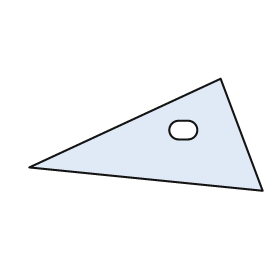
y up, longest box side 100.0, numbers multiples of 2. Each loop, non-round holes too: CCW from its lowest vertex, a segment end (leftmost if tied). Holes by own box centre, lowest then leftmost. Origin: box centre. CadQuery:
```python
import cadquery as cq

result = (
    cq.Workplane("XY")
    .moveTo(50.0, -24.0)
    .lineTo(32.0, 24.0)
    .lineTo(-50.0, -14.0)
    .close()
    .moveTo(14.0, -2.0)
    .lineTo(18.0, -2.0)
    .threePointArc((22.0, 2.0), (18.0, 6.0))
    .lineTo(14.0, 6.0)
    .threePointArc((10.0, 2.0), (14.0, -2.0))
    .close()
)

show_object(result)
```